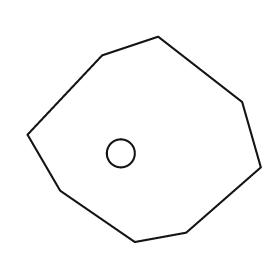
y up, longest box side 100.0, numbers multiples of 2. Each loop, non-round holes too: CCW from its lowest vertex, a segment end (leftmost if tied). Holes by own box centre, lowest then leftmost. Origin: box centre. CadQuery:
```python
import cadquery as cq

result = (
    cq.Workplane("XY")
    .moveTo(-4.0, -44.0)
    .lineTo(18.0, -40.0)
    .lineTo(50.0, -12.0)
    .lineTo(42.0, 16.0)
    .lineTo(6.0, 44.0)
    .lineTo(-18.0, 36.0)
    .lineTo(-50.0, 2.0)
    .lineTo(-36.0, -22.0)
    .close()
    .moveTo(-10.0, -6.0)
    .circle(6.0)
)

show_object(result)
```